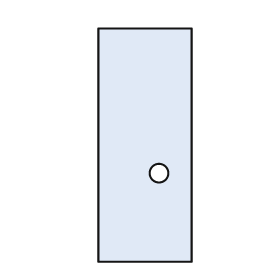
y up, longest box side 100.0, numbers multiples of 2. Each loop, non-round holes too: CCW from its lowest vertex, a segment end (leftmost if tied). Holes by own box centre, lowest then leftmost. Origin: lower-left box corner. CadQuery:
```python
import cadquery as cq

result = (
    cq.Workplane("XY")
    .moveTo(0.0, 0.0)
    .lineTo(40.0, 0.0)
    .lineTo(40.0, 100.0)
    .lineTo(0.0, 100.0)
    .close()
    .moveTo(26.0, 38.0)
    .circle(4.0)
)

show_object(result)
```